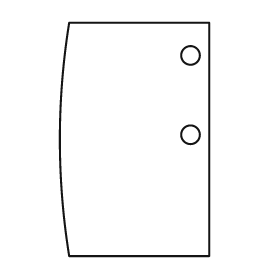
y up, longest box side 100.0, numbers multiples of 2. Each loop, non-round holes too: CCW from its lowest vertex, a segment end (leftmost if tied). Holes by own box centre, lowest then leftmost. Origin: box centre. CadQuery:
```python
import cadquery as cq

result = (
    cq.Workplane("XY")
    .moveTo(-28.0, -50.0)
    .lineTo(32.0, -50.0)
    .lineTo(32.0, 50.0)
    .lineTo(-28.0, 50.0)
    .threePointArc((-32.0, 0.0), (-28.0, -50.0))
    .close()
    .moveTo(24.0, 2.0)
    .circle(4.0)
    .moveTo(24.0, 36.0)
    .circle(4.0)
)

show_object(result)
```